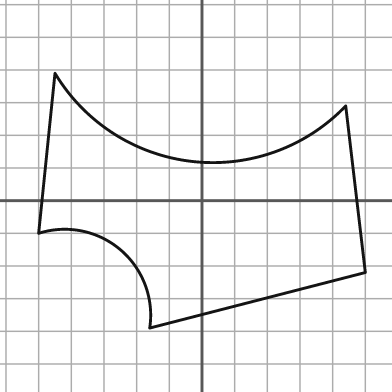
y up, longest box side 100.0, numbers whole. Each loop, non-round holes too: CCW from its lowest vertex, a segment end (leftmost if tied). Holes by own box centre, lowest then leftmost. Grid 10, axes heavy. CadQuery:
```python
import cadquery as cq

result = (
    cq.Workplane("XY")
    .moveTo(-16.0, -39.0)
    .lineTo(50.0, -22.0)
    .lineTo(44.0, 29.0)
    .threePointArc((-3.0, 12.0), (-45.0, 39.0))
    .lineTo(-50.0, -10.0)
    .threePointArc((-25.0, -15.0), (-16.0, -39.0))
    .close()
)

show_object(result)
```